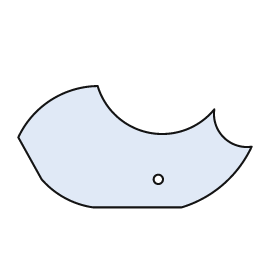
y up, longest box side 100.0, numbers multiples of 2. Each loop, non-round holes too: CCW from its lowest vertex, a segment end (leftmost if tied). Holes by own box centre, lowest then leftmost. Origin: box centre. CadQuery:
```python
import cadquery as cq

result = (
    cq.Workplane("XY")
    .moveTo(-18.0, -26.0)
    .lineTo(20.0, -26.0)
    .threePointArc((38.0, -16.0), (50.0, 0.0))
    .threePointArc((38.0, 4.0), (34.0, 16.0))
    .threePointArc((6.0, 6.0), (-16.0, 26.0))
    .threePointArc((-36.0, 20.0), (-50.0, 4.0))
    .lineTo(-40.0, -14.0)
    .threePointArc((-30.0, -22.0), (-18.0, -26.0))
    .close()
    .moveTo(10.0, -14.0)
    .circle(2.0)
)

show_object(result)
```